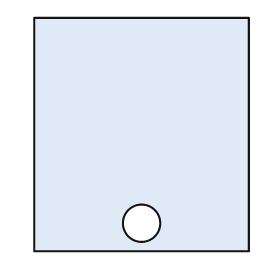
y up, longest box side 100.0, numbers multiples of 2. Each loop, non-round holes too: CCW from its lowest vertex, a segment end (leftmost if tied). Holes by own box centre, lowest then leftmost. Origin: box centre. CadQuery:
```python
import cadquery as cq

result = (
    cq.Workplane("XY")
    .moveTo(-46.0, -50.0)
    .lineTo(46.0, -50.0)
    .lineTo(46.0, 50.0)
    .lineTo(-46.0, 50.0)
    .close()
    .moveTo(0.0, -38.0)
    .circle(8.0)
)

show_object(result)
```